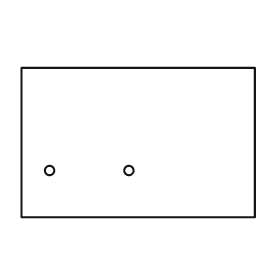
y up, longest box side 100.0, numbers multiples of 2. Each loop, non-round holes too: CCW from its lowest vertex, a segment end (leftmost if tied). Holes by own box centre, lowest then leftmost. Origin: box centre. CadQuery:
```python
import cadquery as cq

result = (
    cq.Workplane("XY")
    .moveTo(-50.0, -32.0)
    .lineTo(50.0, -32.0)
    .lineTo(50.0, 32.0)
    .lineTo(-50.0, 32.0)
    .close()
    .moveTo(-38.0, -12.0)
    .circle(2.0)
    .moveTo(-4.0, -12.0)
    .circle(2.0)
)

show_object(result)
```